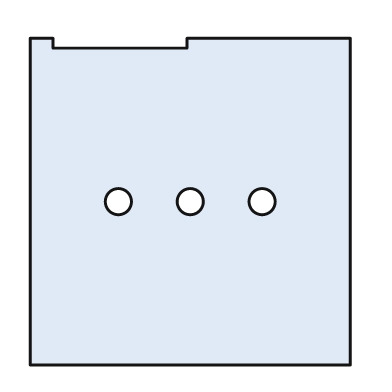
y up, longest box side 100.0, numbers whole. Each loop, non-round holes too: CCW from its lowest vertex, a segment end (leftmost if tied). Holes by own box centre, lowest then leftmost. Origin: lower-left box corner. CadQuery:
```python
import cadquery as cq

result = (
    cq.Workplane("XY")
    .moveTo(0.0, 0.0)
    .lineTo(98.0, 0.0)
    .lineTo(98.0, 100.0)
    .lineTo(48.0, 100.0)
    .lineTo(48.0, 97.0)
    .lineTo(7.0, 97.0)
    .lineTo(7.0, 100.0)
    .lineTo(0.0, 100.0)
    .close()
    .moveTo(27.0, 50.0)
    .circle(4.0)
    .moveTo(49.0, 50.0)
    .circle(4.0)
    .moveTo(71.0, 50.0)
    .circle(4.0)
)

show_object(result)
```